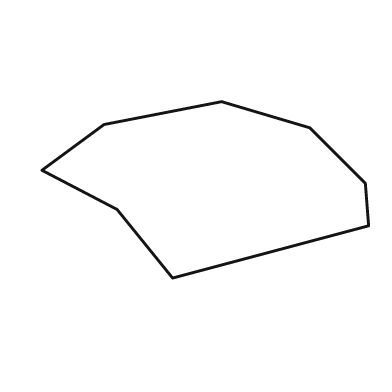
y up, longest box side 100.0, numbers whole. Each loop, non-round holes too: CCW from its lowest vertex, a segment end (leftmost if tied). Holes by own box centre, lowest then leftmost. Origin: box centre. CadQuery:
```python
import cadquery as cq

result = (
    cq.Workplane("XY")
    .moveTo(-10.0, -27.0)
    .lineTo(50.0, -11.0)
    .lineTo(49.0, 2.0)
    .lineTo(32.0, 19.0)
    .lineTo(5.0, 27.0)
    .lineTo(-31.0, 20.0)
    .lineTo(-50.0, 6.0)
    .lineTo(-27.0, -6.0)
    .close()
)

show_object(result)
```